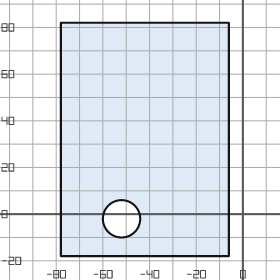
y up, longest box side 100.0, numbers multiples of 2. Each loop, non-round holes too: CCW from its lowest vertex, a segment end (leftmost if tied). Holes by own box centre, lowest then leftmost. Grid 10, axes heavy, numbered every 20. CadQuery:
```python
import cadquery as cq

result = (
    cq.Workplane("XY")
    .moveTo(-78.0, -18.0)
    .lineTo(-6.0, -18.0)
    .lineTo(-6.0, 82.0)
    .lineTo(-78.0, 82.0)
    .close()
    .moveTo(-52.0, -2.0)
    .circle(8.0)
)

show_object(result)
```